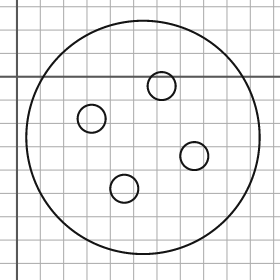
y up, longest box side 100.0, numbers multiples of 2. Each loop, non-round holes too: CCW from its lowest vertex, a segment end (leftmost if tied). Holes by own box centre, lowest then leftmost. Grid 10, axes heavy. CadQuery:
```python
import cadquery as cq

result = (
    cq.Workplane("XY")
    .moveTo(54.0, -26.0)
    .circle(50.0)
    .moveTo(46.0, -48.0)
    .circle(6.0)
    .moveTo(76.0, -34.0)
    .circle(6.0)
    .moveTo(32.0, -18.0)
    .circle(6.0)
    .moveTo(62.0, -4.0)
    .circle(6.0)
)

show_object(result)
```